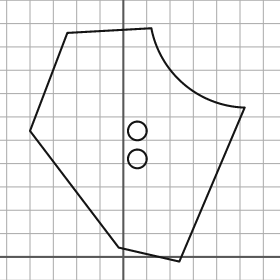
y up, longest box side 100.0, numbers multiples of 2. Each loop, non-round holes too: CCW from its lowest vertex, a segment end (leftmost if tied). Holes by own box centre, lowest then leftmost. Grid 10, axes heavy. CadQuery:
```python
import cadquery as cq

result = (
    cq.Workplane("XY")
    .moveTo(24.0, -2.0)
    .lineTo(52.0, 64.0)
    .threePointArc((26.0, 74.0), (12.0, 98.0))
    .lineTo(-24.0, 96.0)
    .lineTo(-40.0, 54.0)
    .lineTo(-2.0, 4.0)
    .close()
    .moveTo(6.0, 42.0)
    .circle(4.0)
    .moveTo(6.0, 54.0)
    .circle(4.0)
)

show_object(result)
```